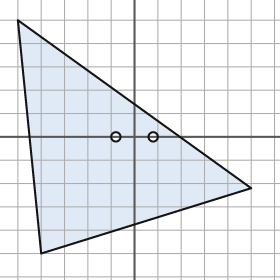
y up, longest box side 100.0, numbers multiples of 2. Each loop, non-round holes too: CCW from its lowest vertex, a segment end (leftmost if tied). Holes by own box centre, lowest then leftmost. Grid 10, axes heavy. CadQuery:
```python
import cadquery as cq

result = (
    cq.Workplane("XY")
    .moveTo(-40.0, -50.0)
    .lineTo(50.0, -22.0)
    .lineTo(-50.0, 50.0)
    .close()
    .moveTo(-8.0, 0.0)
    .circle(2.0)
    .moveTo(8.0, 0.0)
    .circle(2.0)
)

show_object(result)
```